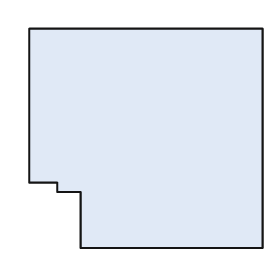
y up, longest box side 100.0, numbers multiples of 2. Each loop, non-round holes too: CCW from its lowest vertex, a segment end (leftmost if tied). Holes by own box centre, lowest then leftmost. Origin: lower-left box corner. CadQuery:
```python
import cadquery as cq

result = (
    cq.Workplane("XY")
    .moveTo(22.0, 0.0)
    .lineTo(100.0, 0.0)
    .lineTo(100.0, 94.0)
    .lineTo(0.0, 94.0)
    .lineTo(0.0, 28.0)
    .lineTo(12.0, 28.0)
    .lineTo(12.0, 24.0)
    .lineTo(22.0, 24.0)
    .close()
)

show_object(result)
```